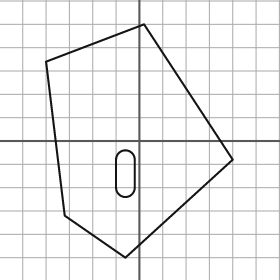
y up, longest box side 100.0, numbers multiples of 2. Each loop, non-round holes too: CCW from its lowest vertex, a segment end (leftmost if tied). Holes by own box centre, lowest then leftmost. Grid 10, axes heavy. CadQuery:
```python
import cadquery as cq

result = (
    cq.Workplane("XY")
    .moveTo(-6.0, -50.0)
    .lineTo(40.0, -8.0)
    .lineTo(2.0, 50.0)
    .lineTo(-40.0, 34.0)
    .lineTo(-32.0, -32.0)
    .close()
    .moveTo(-10.0, -20.0)
    .threePointArc((-6.0, -24.0), (-2.0, -20.0))
    .lineTo(-2.0, -8.0)
    .threePointArc((-6.0, -4.0), (-10.0, -8.0))
    .close()
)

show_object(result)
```